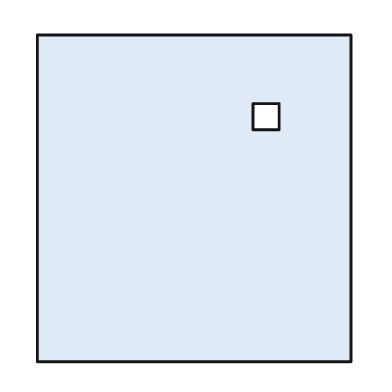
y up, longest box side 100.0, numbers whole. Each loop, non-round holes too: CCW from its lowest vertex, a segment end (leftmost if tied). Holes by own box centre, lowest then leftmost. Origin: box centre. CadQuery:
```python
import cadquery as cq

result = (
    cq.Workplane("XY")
    .moveTo(-48.0, -50.0)
    .lineTo(48.0, -50.0)
    .lineTo(48.0, 50.0)
    .lineTo(-48.0, 50.0)
    .close()
    .moveTo(18.0, 21.0)
    .lineTo(26.0, 21.0)
    .lineTo(26.0, 29.0)
    .lineTo(18.0, 29.0)
    .close()
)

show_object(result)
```